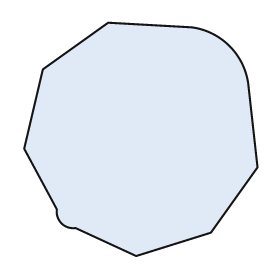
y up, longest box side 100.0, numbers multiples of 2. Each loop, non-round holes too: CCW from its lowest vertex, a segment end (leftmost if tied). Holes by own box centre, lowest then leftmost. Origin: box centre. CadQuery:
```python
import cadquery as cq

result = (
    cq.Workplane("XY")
    .moveTo(-2.0, -50.0)
    .lineTo(30.0, -40.0)
    .lineTo(50.0, -12.0)
    .lineTo(46.0, 24.0)
    .threePointArc((38.0, 40.0), (22.0, 48.0))
    .lineTo(-14.0, 50.0)
    .lineTo(-42.0, 30.0)
    .lineTo(-50.0, -4.0)
    .lineTo(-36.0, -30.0)
    .threePointArc((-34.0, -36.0), (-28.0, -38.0))
    .close()
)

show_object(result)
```